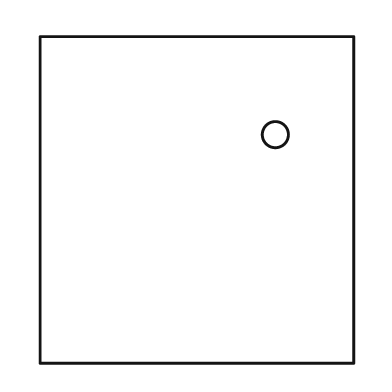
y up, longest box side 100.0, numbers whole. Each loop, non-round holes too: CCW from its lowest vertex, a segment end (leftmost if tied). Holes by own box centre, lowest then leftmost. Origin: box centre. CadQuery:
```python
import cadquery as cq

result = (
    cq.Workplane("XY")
    .moveTo(-48.0, -50.0)
    .lineTo(48.0, -50.0)
    .lineTo(48.0, 50.0)
    .lineTo(-48.0, 50.0)
    .close()
    .moveTo(24.0, 20.0)
    .circle(4.0)
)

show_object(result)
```